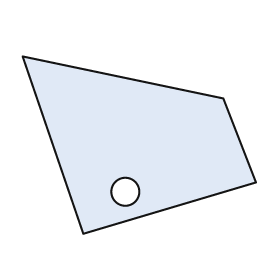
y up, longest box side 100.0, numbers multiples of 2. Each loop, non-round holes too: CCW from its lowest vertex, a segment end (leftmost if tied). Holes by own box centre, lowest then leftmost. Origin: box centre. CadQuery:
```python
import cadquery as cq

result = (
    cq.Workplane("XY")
    .moveTo(-24.0, -38.0)
    .lineTo(50.0, -16.0)
    .lineTo(36.0, 20.0)
    .lineTo(-50.0, 38.0)
    .close()
    .moveTo(-6.0, -20.0)
    .circle(6.0)
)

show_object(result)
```